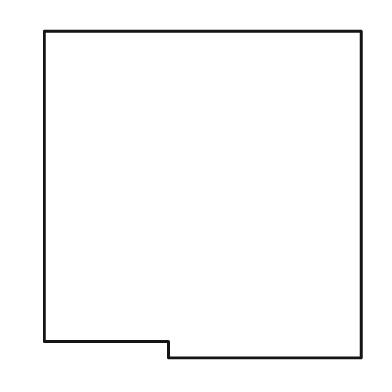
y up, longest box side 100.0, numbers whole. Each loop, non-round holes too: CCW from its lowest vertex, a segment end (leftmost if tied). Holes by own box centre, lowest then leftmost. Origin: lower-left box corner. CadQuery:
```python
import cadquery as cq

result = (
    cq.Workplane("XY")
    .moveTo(38.0, 0.0)
    .lineTo(97.0, 0.0)
    .lineTo(97.0, 100.0)
    .lineTo(0.0, 100.0)
    .lineTo(0.0, 5.0)
    .lineTo(38.0, 5.0)
    .close()
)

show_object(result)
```